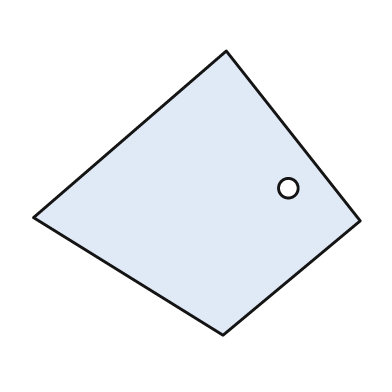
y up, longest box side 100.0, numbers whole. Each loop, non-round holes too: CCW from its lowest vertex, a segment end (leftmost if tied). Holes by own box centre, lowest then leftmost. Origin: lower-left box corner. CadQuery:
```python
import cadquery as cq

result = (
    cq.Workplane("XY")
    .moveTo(58.0, 0.0)
    .lineTo(100.0, 35.0)
    .lineTo(59.0, 87.0)
    .lineTo(0.0, 36.0)
    .close()
    .moveTo(78.0, 45.0)
    .circle(3.0)
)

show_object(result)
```